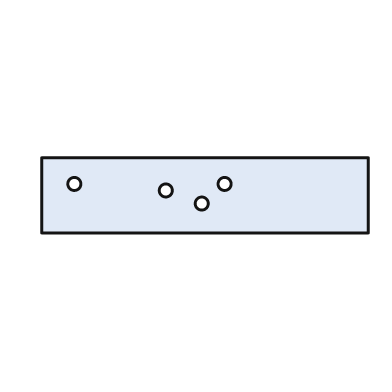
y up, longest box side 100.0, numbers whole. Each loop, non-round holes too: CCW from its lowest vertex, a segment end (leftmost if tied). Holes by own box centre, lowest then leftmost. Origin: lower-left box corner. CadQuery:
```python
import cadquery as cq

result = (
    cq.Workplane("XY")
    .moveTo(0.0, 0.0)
    .lineTo(100.0, 0.0)
    .lineTo(100.0, 23.0)
    .lineTo(0.0, 23.0)
    .close()
    .moveTo(49.0, 9.0)
    .circle(2.0)
    .moveTo(38.0, 13.0)
    .circle(2.0)
    .moveTo(10.0, 15.0)
    .circle(2.0)
    .moveTo(56.0, 15.0)
    .circle(2.0)
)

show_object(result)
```